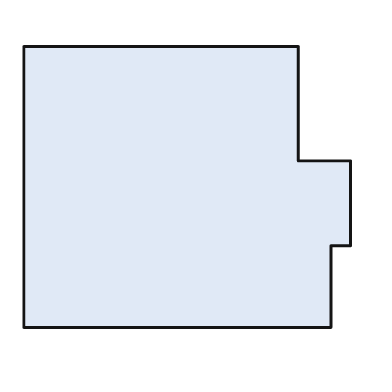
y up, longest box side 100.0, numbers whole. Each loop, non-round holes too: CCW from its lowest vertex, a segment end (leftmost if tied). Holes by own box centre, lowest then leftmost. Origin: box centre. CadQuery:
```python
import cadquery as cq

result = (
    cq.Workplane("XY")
    .moveTo(-50.0, -43.0)
    .lineTo(44.0, -43.0)
    .lineTo(44.0, -18.0)
    .lineTo(50.0, -18.0)
    .lineTo(50.0, 8.0)
    .lineTo(34.0, 8.0)
    .lineTo(34.0, 43.0)
    .lineTo(-50.0, 43.0)
    .close()
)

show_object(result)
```